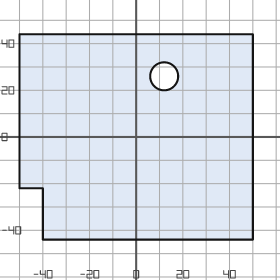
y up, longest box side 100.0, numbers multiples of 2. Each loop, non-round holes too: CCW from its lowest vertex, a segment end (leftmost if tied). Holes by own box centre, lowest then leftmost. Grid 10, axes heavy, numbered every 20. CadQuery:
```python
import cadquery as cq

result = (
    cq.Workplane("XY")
    .moveTo(-40.0, -44.0)
    .lineTo(50.0, -44.0)
    .lineTo(50.0, 44.0)
    .lineTo(-50.0, 44.0)
    .lineTo(-50.0, -22.0)
    .lineTo(-40.0, -22.0)
    .close()
    .moveTo(12.0, 26.0)
    .circle(6.0)
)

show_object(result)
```